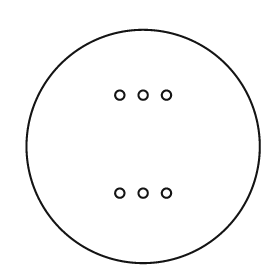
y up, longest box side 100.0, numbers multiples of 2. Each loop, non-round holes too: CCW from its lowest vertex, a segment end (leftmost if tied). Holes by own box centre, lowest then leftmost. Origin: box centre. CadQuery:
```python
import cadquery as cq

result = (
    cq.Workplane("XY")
    .moveTo(0.0, 0.0)
    .circle(50.0)
    .moveTo(-10.0, -20.0)
    .circle(2.0)
    .moveTo(0.0, -20.0)
    .circle(2.0)
    .moveTo(10.0, -20.0)
    .circle(2.0)
    .moveTo(-10.0, 22.0)
    .circle(2.0)
    .moveTo(0.0, 22.0)
    .circle(2.0)
    .moveTo(10.0, 22.0)
    .circle(2.0)
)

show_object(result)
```